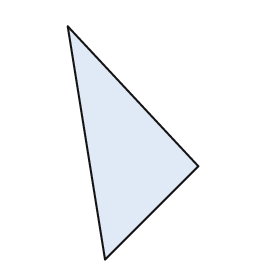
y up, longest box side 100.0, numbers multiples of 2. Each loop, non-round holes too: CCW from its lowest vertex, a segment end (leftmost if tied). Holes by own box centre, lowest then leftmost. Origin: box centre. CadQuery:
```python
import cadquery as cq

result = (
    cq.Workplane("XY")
    .moveTo(-12.0, -50.0)
    .lineTo(28.0, -10.0)
    .lineTo(-28.0, 50.0)
    .close()
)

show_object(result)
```